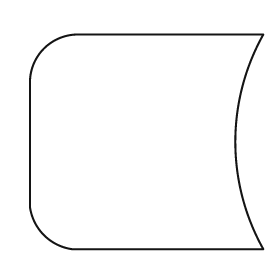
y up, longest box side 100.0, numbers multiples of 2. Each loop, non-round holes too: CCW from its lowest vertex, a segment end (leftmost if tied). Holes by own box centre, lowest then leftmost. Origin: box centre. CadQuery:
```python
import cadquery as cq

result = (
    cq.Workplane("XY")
    .moveTo(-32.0, -46.0)
    .lineTo(50.0, -46.0)
    .threePointArc((38.0, 0.0), (50.0, 46.0))
    .lineTo(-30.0, 46.0)
    .threePointArc((-44.0, 40.0), (-50.0, 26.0))
    .lineTo(-50.0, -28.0)
    .threePointArc((-44.0, -40.0), (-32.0, -46.0))
    .close()
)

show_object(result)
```